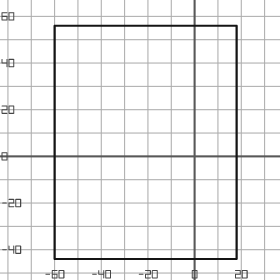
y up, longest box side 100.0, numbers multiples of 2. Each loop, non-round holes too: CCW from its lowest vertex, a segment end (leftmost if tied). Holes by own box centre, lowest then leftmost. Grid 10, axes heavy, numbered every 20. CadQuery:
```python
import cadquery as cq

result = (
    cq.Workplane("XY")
    .moveTo(-60.0, -44.0)
    .lineTo(18.0, -44.0)
    .lineTo(18.0, 56.0)
    .lineTo(-60.0, 56.0)
    .close()
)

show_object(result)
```